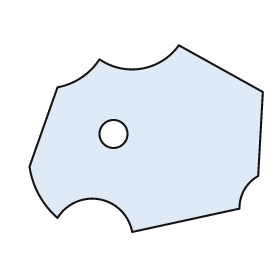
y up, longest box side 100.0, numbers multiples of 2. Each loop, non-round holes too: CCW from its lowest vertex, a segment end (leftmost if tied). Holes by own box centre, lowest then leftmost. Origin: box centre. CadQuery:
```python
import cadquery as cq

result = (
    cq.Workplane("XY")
    .moveTo(-6.0, -40.0)
    .lineTo(40.0, -30.0)
    .threePointArc((42.0, -22.0), (48.0, -16.0))
    .lineTo(50.0, 20.0)
    .lineTo(14.0, 40.0)
    .threePointArc((-2.0, 30.0), (-20.0, 34.0))
    .threePointArc((-28.0, 26.0), (-38.0, 22.0))
    .lineTo(-50.0, -12.0)
    .threePointArc((-46.0, -24.0), (-38.0, -34.0))
    .threePointArc((-20.0, -26.0), (-6.0, -40.0))
    .close()
    .moveTo(-14.0, 2.0)
    .circle(6.0)
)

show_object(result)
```